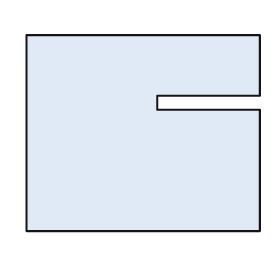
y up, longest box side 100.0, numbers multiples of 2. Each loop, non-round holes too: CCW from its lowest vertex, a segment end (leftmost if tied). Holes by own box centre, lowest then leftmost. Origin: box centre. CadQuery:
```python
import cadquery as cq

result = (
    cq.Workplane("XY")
    .moveTo(-50.0, -42.0)
    .lineTo(50.0, -42.0)
    .lineTo(50.0, 10.0)
    .lineTo(6.0, 10.0)
    .lineTo(6.0, 16.0)
    .lineTo(50.0, 16.0)
    .lineTo(50.0, 42.0)
    .lineTo(-50.0, 42.0)
    .close()
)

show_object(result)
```